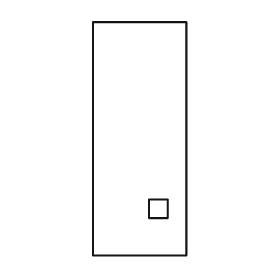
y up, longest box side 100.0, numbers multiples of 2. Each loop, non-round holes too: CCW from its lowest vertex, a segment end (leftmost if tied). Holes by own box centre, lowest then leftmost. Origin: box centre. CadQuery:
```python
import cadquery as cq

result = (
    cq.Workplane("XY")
    .moveTo(-20.0, -50.0)
    .lineTo(20.0, -50.0)
    .lineTo(20.0, 50.0)
    .lineTo(-20.0, 50.0)
    .close()
    .moveTo(4.0, -34.0)
    .lineTo(12.0, -34.0)
    .lineTo(12.0, -26.0)
    .lineTo(4.0, -26.0)
    .close()
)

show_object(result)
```